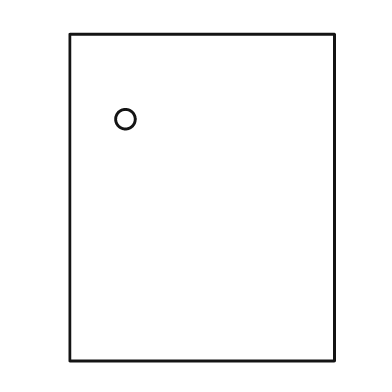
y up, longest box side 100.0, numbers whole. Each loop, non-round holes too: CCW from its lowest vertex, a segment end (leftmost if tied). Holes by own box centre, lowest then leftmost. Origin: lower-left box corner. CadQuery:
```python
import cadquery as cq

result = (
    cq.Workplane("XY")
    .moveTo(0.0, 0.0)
    .lineTo(81.0, 0.0)
    .lineTo(81.0, 100.0)
    .lineTo(0.0, 100.0)
    .close()
    .moveTo(17.0, 74.0)
    .circle(3.0)
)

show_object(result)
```